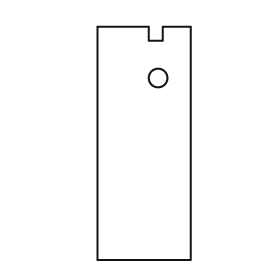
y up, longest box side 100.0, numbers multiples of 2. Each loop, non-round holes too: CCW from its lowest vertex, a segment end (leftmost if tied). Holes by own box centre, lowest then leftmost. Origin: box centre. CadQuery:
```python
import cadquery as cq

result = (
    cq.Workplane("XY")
    .moveTo(-20.0, -50.0)
    .lineTo(20.0, -50.0)
    .lineTo(20.0, 50.0)
    .lineTo(8.0, 50.0)
    .lineTo(8.0, 44.0)
    .lineTo(2.0, 44.0)
    .lineTo(2.0, 50.0)
    .lineTo(-20.0, 50.0)
    .close()
    .moveTo(6.0, 28.0)
    .circle(4.0)
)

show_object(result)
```